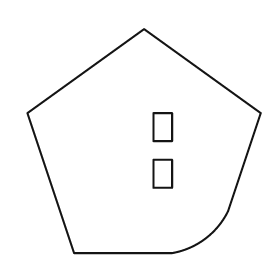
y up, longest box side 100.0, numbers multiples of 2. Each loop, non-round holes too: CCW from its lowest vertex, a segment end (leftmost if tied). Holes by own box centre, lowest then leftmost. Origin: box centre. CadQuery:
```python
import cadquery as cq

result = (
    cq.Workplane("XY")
    .moveTo(-30.0, -48.0)
    .lineTo(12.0, -48.0)
    .threePointArc((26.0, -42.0), (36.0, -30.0))
    .lineTo(50.0, 12.0)
    .lineTo(0.0, 48.0)
    .lineTo(-50.0, 12.0)
    .close()
    .moveTo(4.0, -20.0)
    .lineTo(12.0, -20.0)
    .lineTo(12.0, -8.0)
    .lineTo(4.0, -8.0)
    .close()
    .moveTo(4.0, 0.0)
    .lineTo(12.0, 0.0)
    .lineTo(12.0, 12.0)
    .lineTo(4.0, 12.0)
    .close()
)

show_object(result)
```